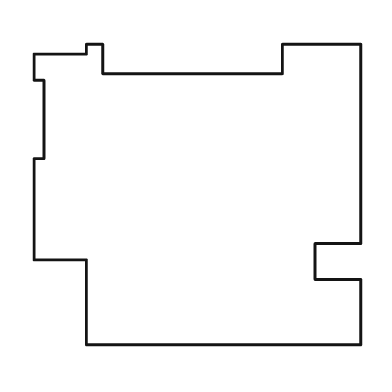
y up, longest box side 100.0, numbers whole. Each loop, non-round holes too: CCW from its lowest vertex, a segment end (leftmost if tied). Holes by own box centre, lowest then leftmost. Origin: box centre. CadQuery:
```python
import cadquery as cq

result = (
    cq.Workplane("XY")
    .moveTo(-34.0, -46.0)
    .lineTo(50.0, -46.0)
    .lineTo(50.0, -26.0)
    .lineTo(36.0, -26.0)
    .lineTo(36.0, -15.0)
    .lineTo(50.0, -15.0)
    .lineTo(50.0, 46.0)
    .lineTo(26.0, 46.0)
    .lineTo(26.0, 37.0)
    .lineTo(-29.0, 37.0)
    .lineTo(-29.0, 46.0)
    .lineTo(-34.0, 46.0)
    .lineTo(-34.0, 43.0)
    .lineTo(-50.0, 43.0)
    .lineTo(-50.0, 35.0)
    .lineTo(-47.0, 35.0)
    .lineTo(-47.0, 11.0)
    .lineTo(-50.0, 11.0)
    .lineTo(-50.0, -20.0)
    .lineTo(-34.0, -20.0)
    .close()
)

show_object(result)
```